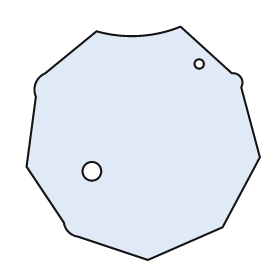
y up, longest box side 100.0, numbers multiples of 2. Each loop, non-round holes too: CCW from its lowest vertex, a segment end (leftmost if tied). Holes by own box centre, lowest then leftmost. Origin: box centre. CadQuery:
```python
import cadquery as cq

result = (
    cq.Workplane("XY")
    .moveTo(2.0, -50.0)
    .lineTo(34.0, -36.0)
    .lineTo(50.0, -6.0)
    .lineTo(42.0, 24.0)
    .threePointArc((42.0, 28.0), (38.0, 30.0))
    .lineTo(16.0, 50.0)
    .threePointArc((-2.0, 46.0), (-20.0, 48.0))
    .lineTo(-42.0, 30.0)
    .threePointArc((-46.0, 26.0), (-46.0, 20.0))
    .lineTo(-50.0, -10.0)
    .lineTo(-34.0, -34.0)
    .threePointArc((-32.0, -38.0), (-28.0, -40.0))
    .close()
    .moveTo(-22.0, -12.0)
    .circle(4.0)
    .moveTo(24.0, 34.0)
    .circle(2.0)
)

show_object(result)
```